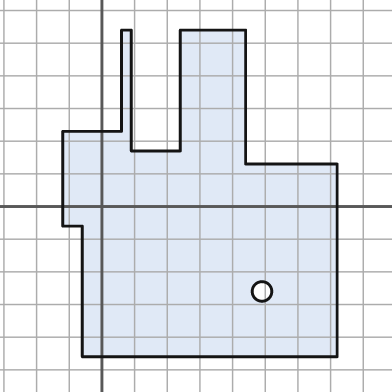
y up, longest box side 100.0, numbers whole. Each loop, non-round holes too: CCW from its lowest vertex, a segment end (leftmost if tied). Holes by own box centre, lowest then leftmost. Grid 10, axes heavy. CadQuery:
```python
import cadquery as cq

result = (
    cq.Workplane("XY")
    .moveTo(-6.0, -46.0)
    .lineTo(72.0, -46.0)
    .lineTo(72.0, 13.0)
    .lineTo(44.0, 13.0)
    .lineTo(44.0, 54.0)
    .lineTo(24.0, 54.0)
    .lineTo(24.0, 17.0)
    .lineTo(9.0, 17.0)
    .lineTo(9.0, 54.0)
    .lineTo(6.0, 54.0)
    .lineTo(6.0, 23.0)
    .lineTo(-12.0, 23.0)
    .lineTo(-12.0, -6.0)
    .lineTo(-6.0, -6.0)
    .close()
    .moveTo(49.0, -26.0)
    .circle(3.0)
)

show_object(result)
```